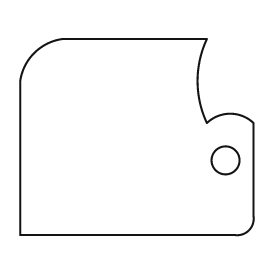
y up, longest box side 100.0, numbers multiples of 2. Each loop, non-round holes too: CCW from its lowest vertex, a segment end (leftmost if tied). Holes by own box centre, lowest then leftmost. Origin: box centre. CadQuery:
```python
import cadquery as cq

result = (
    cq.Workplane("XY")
    .moveTo(-50.0, -42.0)
    .lineTo(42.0, -42.0)
    .threePointArc((48.0, -40.0), (50.0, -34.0))
    .lineTo(50.0, 6.0)
    .threePointArc((40.0, 10.0), (30.0, 6.0))
    .threePointArc((26.0, 24.0), (30.0, 42.0))
    .lineTo(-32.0, 42.0)
    .threePointArc((-44.0, 36.0), (-50.0, 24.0))
    .close()
    .moveTo(38.0, -10.0)
    .circle(6.0)
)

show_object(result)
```